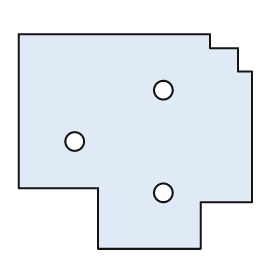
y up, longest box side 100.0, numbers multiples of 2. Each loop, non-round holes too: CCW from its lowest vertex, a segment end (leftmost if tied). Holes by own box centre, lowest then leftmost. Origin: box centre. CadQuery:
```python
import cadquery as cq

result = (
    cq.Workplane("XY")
    .moveTo(-16.0, -46.0)
    .lineTo(28.0, -46.0)
    .lineTo(28.0, -26.0)
    .lineTo(50.0, -26.0)
    .lineTo(50.0, 30.0)
    .lineTo(44.0, 30.0)
    .lineTo(44.0, 40.0)
    .lineTo(32.0, 40.0)
    .lineTo(32.0, 46.0)
    .lineTo(-50.0, 46.0)
    .lineTo(-50.0, -20.0)
    .lineTo(-16.0, -20.0)
    .close()
    .moveTo(12.0, -22.0)
    .circle(4.0)
    .moveTo(-26.0, 0.0)
    .circle(4.0)
    .moveTo(12.0, 22.0)
    .circle(4.0)
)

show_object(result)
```